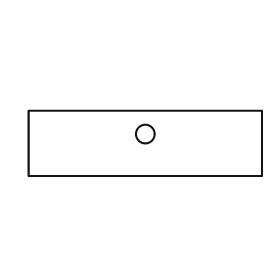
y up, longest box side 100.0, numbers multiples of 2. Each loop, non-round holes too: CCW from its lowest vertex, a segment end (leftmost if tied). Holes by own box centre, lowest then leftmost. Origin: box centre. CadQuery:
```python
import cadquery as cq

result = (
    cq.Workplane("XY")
    .moveTo(-50.0, -14.0)
    .lineTo(50.0, -14.0)
    .lineTo(50.0, 14.0)
    .lineTo(-50.0, 14.0)
    .close()
    .moveTo(0.0, 4.0)
    .circle(4.0)
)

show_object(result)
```